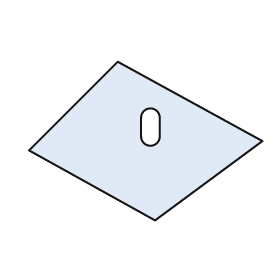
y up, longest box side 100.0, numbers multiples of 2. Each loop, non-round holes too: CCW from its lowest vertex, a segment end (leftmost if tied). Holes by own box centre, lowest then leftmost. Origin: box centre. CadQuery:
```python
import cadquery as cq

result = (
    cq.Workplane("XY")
    .moveTo(4.0, -34.0)
    .lineTo(50.0, 0.0)
    .lineTo(-12.0, 34.0)
    .lineTo(-50.0, -4.0)
    .close()
    .moveTo(-2.0, 2.0)
    .threePointArc((2.0, -2.0), (6.0, 2.0))
    .lineTo(6.0, 10.0)
    .threePointArc((2.0, 14.0), (-2.0, 10.0))
    .close()
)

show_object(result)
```